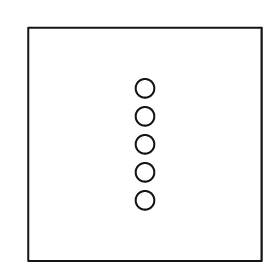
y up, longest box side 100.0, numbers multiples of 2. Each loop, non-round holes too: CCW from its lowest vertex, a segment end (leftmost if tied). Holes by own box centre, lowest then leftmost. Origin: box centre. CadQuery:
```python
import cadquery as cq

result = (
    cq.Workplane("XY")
    .moveTo(-50.0, -50.0)
    .lineTo(50.0, -50.0)
    .lineTo(50.0, 50.0)
    .lineTo(-50.0, 50.0)
    .close()
    .moveTo(0.0, -24.0)
    .circle(4.0)
    .moveTo(0.0, -12.0)
    .circle(4.0)
    .moveTo(0.0, 0.0)
    .circle(4.0)
    .moveTo(0.0, 12.0)
    .circle(4.0)
    .moveTo(0.0, 24.0)
    .circle(4.0)
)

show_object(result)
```